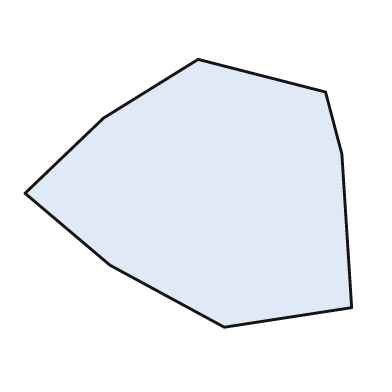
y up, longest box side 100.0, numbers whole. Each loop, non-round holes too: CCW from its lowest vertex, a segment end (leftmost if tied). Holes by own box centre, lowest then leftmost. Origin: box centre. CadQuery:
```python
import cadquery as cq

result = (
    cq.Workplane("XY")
    .moveTo(11.0, -41.0)
    .lineTo(50.0, -35.0)
    .lineTo(47.0, 12.0)
    .lineTo(42.0, 31.0)
    .lineTo(3.0, 41.0)
    .lineTo(-26.0, 23.0)
    .lineTo(-50.0, 0.0)
    .lineTo(-24.0, -22.0)
    .close()
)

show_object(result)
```